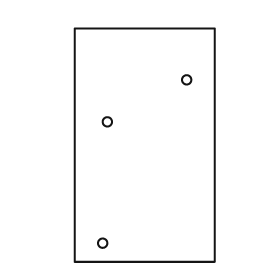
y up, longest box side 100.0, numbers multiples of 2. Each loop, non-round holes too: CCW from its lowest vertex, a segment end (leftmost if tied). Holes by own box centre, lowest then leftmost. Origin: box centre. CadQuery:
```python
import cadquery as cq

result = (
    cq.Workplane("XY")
    .moveTo(-30.0, -50.0)
    .lineTo(30.0, -50.0)
    .lineTo(30.0, 50.0)
    .lineTo(-30.0, 50.0)
    .close()
    .moveTo(-18.0, -42.0)
    .circle(2.0)
    .moveTo(-16.0, 10.0)
    .circle(2.0)
    .moveTo(18.0, 28.0)
    .circle(2.0)
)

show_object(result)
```